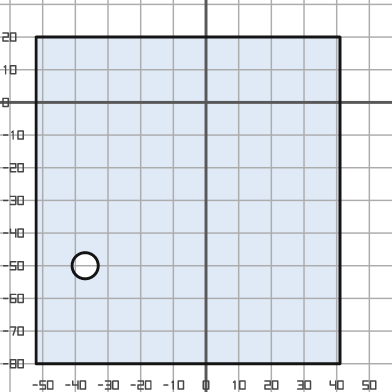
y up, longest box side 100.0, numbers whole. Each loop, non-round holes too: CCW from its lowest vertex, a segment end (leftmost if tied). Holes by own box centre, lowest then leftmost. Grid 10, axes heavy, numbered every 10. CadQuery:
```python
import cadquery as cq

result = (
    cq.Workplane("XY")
    .moveTo(-52.0, -80.0)
    .lineTo(41.0, -80.0)
    .lineTo(41.0, 20.0)
    .lineTo(-52.0, 20.0)
    .close()
    .moveTo(-37.0, -50.0)
    .circle(4.0)
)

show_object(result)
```